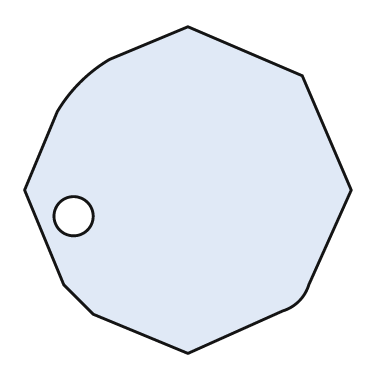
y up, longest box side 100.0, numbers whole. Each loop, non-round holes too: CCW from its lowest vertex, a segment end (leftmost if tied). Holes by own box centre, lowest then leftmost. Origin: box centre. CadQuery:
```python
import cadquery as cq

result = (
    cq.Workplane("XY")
    .moveTo(0.0, -50.0)
    .lineTo(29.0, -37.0)
    .threePointArc((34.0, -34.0), (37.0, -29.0))
    .lineTo(50.0, 0.0)
    .lineTo(35.0, 35.0)
    .lineTo(0.0, 50.0)
    .lineTo(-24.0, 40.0)
    .threePointArc((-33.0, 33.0), (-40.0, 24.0))
    .lineTo(-50.0, 0.0)
    .lineTo(-38.0, -29.0)
    .lineTo(-29.0, -38.0)
    .close()
    .moveTo(-35.0, -8.0)
    .circle(6.0)
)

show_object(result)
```